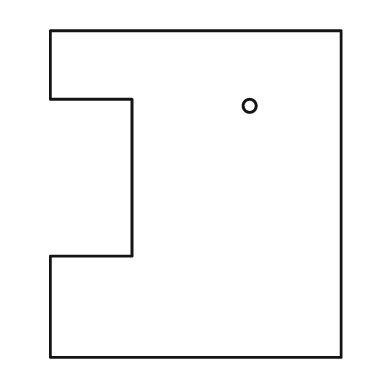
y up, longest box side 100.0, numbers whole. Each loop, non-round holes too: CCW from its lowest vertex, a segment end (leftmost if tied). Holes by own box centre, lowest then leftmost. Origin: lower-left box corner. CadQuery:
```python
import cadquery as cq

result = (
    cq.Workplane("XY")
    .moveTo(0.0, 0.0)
    .lineTo(89.0, 0.0)
    .lineTo(89.0, 100.0)
    .lineTo(0.0, 100.0)
    .lineTo(0.0, 79.0)
    .lineTo(25.0, 79.0)
    .lineTo(25.0, 31.0)
    .lineTo(0.0, 31.0)
    .close()
    .moveTo(61.0, 77.0)
    .circle(2.0)
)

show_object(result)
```